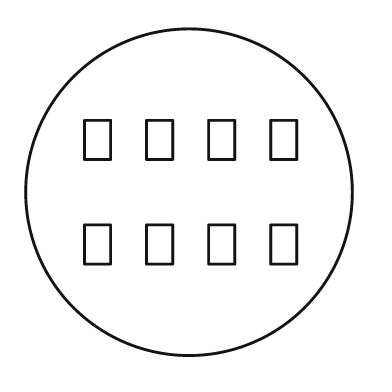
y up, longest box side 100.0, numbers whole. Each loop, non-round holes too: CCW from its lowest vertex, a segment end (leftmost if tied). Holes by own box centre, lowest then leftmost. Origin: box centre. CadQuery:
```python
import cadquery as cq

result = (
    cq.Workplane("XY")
    .moveTo(0.0, 0.0)
    .circle(50.0)
    .moveTo(-32.0, -22.0)
    .lineTo(-24.0, -22.0)
    .lineTo(-24.0, -10.0)
    .lineTo(-32.0, -10.0)
    .close()
    .moveTo(-13.0, -22.0)
    .lineTo(-5.0, -22.0)
    .lineTo(-5.0, -10.0)
    .lineTo(-13.0, -10.0)
    .close()
    .moveTo(6.0, -22.0)
    .lineTo(14.0, -22.0)
    .lineTo(14.0, -10.0)
    .lineTo(6.0, -10.0)
    .close()
    .moveTo(25.0, -22.0)
    .lineTo(33.0, -22.0)
    .lineTo(33.0, -10.0)
    .lineTo(25.0, -10.0)
    .close()
    .moveTo(-32.0, 10.0)
    .lineTo(-24.0, 10.0)
    .lineTo(-24.0, 22.0)
    .lineTo(-32.0, 22.0)
    .close()
    .moveTo(-13.0, 10.0)
    .lineTo(-5.0, 10.0)
    .lineTo(-5.0, 22.0)
    .lineTo(-13.0, 22.0)
    .close()
    .moveTo(6.0, 10.0)
    .lineTo(14.0, 10.0)
    .lineTo(14.0, 22.0)
    .lineTo(6.0, 22.0)
    .close()
    .moveTo(25.0, 10.0)
    .lineTo(33.0, 10.0)
    .lineTo(33.0, 22.0)
    .lineTo(25.0, 22.0)
    .close()
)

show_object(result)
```